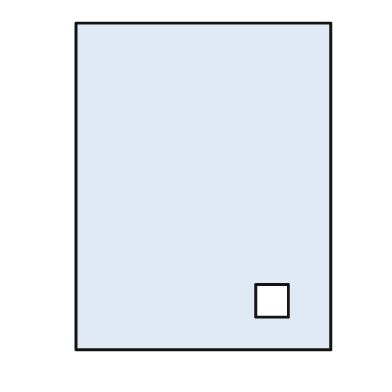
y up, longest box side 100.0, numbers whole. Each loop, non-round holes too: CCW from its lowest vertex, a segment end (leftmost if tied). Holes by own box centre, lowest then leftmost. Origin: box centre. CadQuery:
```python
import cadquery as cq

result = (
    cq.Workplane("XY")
    .moveTo(-39.0, -50.0)
    .lineTo(39.0, -50.0)
    .lineTo(39.0, 50.0)
    .lineTo(-39.0, 50.0)
    .close()
    .moveTo(16.0, -40.0)
    .lineTo(26.0, -40.0)
    .lineTo(26.0, -30.0)
    .lineTo(16.0, -30.0)
    .close()
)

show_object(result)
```